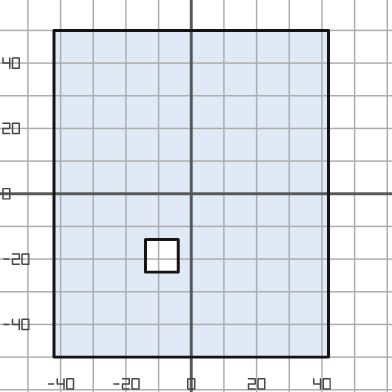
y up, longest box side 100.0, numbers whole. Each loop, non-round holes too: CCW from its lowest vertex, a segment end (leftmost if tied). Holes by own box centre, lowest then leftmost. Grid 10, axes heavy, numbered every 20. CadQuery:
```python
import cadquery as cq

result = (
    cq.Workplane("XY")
    .moveTo(-42.0, -50.0)
    .lineTo(42.0, -50.0)
    .lineTo(42.0, 50.0)
    .lineTo(-42.0, 50.0)
    .close()
    .moveTo(-14.0, -24.0)
    .lineTo(-4.0, -24.0)
    .lineTo(-4.0, -14.0)
    .lineTo(-14.0, -14.0)
    .close()
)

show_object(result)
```